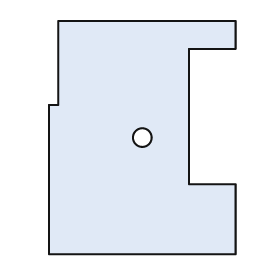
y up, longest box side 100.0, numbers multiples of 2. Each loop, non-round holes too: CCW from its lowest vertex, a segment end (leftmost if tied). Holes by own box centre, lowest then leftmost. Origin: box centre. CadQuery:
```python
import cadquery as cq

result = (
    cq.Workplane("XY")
    .moveTo(-40.0, -50.0)
    .lineTo(40.0, -50.0)
    .lineTo(40.0, -20.0)
    .lineTo(20.0, -20.0)
    .lineTo(20.0, 38.0)
    .lineTo(40.0, 38.0)
    .lineTo(40.0, 50.0)
    .lineTo(-36.0, 50.0)
    .lineTo(-36.0, 14.0)
    .lineTo(-40.0, 14.0)
    .close()
    .moveTo(0.0, 0.0)
    .circle(4.0)
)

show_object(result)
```